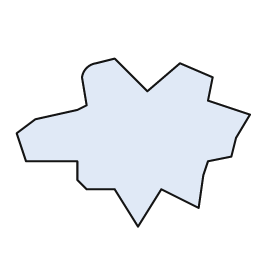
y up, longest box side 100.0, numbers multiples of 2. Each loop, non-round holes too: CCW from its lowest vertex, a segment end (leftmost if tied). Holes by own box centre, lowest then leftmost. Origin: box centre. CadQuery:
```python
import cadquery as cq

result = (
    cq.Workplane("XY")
    .moveTo(2.0, -36.0)
    .lineTo(12.0, -20.0)
    .lineTo(28.0, -28.0)
    .lineTo(30.0, -14.0)
    .lineTo(32.0, -8.0)
    .lineTo(42.0, -6.0)
    .lineTo(44.0, 2.0)
    .lineTo(50.0, 12.0)
    .lineTo(32.0, 18.0)
    .lineTo(34.0, 28.0)
    .lineTo(20.0, 34.0)
    .lineTo(6.0, 22.0)
    .lineTo(-8.0, 36.0)
    .lineTo(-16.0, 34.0)
    .threePointArc((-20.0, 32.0), (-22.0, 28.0))
    .lineTo(-20.0, 16.0)
    .lineTo(-24.0, 14.0)
    .lineTo(-42.0, 10.0)
    .lineTo(-50.0, 4.0)
    .lineTo(-46.0, -8.0)
    .lineTo(-24.0, -8.0)
    .lineTo(-24.0, -16.0)
    .lineTo(-20.0, -20.0)
    .lineTo(-8.0, -20.0)
    .close()
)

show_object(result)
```